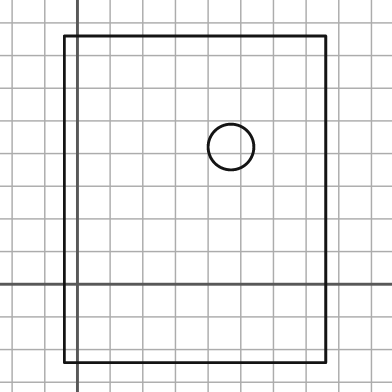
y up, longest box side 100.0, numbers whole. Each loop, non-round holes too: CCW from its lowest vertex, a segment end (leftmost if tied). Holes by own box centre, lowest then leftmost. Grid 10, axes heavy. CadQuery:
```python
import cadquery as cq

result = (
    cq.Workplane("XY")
    .moveTo(-4.0, -24.0)
    .lineTo(76.0, -24.0)
    .lineTo(76.0, 76.0)
    .lineTo(-4.0, 76.0)
    .close()
    .moveTo(47.0, 42.0)
    .circle(7.0)
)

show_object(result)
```